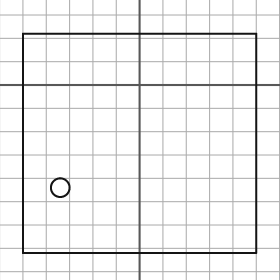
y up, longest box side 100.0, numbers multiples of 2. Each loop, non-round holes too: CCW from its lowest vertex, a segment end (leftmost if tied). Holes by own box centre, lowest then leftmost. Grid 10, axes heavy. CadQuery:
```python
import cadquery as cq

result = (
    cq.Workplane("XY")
    .moveTo(-50.0, -72.0)
    .lineTo(50.0, -72.0)
    .lineTo(50.0, 22.0)
    .lineTo(-50.0, 22.0)
    .close()
    .moveTo(-34.0, -44.0)
    .circle(4.0)
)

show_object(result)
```